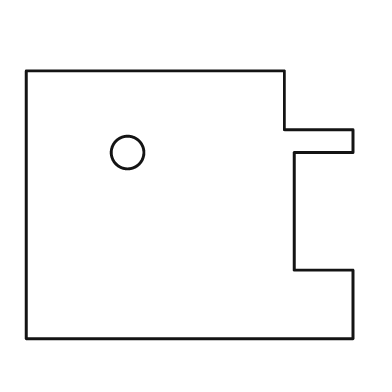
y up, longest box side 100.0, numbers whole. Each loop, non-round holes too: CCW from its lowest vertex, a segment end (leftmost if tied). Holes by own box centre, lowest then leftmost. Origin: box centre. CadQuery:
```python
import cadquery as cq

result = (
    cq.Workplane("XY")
    .moveTo(-50.0, -41.0)
    .lineTo(50.0, -41.0)
    .lineTo(50.0, -20.0)
    .lineTo(32.0, -20.0)
    .lineTo(32.0, 16.0)
    .lineTo(50.0, 16.0)
    .lineTo(50.0, 23.0)
    .lineTo(29.0, 23.0)
    .lineTo(29.0, 41.0)
    .lineTo(-50.0, 41.0)
    .close()
    .moveTo(-19.0, 16.0)
    .circle(5.0)
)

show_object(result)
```